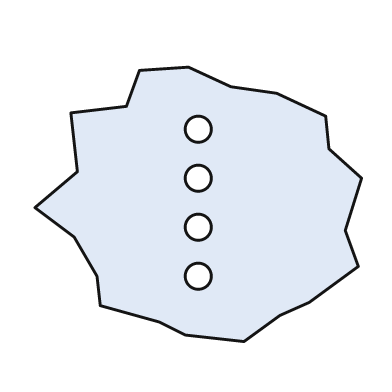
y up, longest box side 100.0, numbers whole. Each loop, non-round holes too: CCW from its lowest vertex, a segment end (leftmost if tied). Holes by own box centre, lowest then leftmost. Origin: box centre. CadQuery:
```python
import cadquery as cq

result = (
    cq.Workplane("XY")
    .moveTo(14.0, -42.0)
    .lineTo(25.0, -34.0)
    .lineTo(34.0, -30.0)
    .lineTo(49.0, -19.0)
    .lineTo(45.0, -8.0)
    .lineTo(50.0, 8.0)
    .lineTo(40.0, 17.0)
    .lineTo(39.0, 27.0)
    .lineTo(24.0, 34.0)
    .lineTo(10.0, 36.0)
    .lineTo(-3.0, 42.0)
    .lineTo(-18.0, 41.0)
    .lineTo(-22.0, 30.0)
    .lineTo(-39.0, 28.0)
    .lineTo(-37.0, 10.0)
    .lineTo(-50.0, -1.0)
    .lineTo(-38.0, -10.0)
    .lineTo(-31.0, -22.0)
    .lineTo(-30.0, -31.0)
    .lineTo(-12.0, -36.0)
    .lineTo(-4.0, -40.0)
    .close()
    .moveTo(0.0, -22.0)
    .circle(4.0)
    .moveTo(0.0, -7.0)
    .circle(4.0)
    .moveTo(0.0, 8.0)
    .circle(4.0)
    .moveTo(0.0, 23.0)
    .circle(4.0)
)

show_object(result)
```